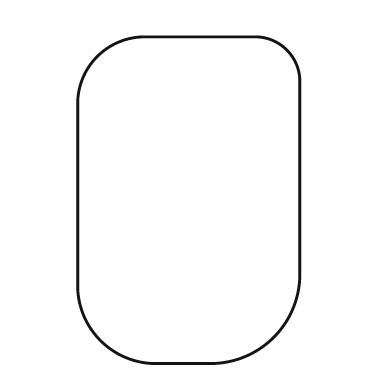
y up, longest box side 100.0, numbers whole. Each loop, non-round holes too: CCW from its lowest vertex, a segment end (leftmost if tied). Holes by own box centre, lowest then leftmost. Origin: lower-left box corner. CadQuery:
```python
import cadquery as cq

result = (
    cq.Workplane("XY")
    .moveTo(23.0, 0.0)
    .lineTo(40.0, 0.0)
    .threePointArc((60.0, 8.0), (68.0, 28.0))
    .lineTo(68.0, 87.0)
    .threePointArc((64.0, 96.0), (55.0, 100.0))
    .lineTo(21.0, 100.0)
    .threePointArc((6.0, 94.0), (0.0, 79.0))
    .lineTo(0.0, 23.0)
    .threePointArc((7.0, 7.0), (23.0, 0.0))
    .close()
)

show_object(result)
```